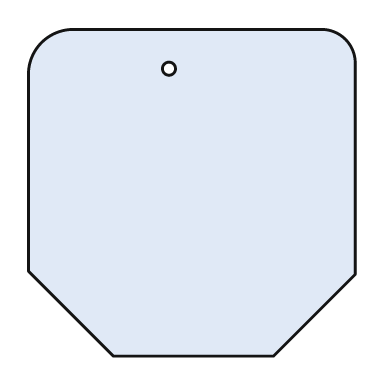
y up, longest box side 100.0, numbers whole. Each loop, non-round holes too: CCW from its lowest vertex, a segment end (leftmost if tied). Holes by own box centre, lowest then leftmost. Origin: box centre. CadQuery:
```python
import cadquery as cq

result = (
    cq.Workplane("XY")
    .moveTo(-24.0, -50.0)
    .lineTo(25.0, -50.0)
    .lineTo(50.0, -25.0)
    .lineTo(50.0, 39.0)
    .threePointArc((47.0, 47.0), (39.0, 50.0))
    .lineTo(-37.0, 50.0)
    .threePointArc((-46.0, 46.0), (-50.0, 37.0))
    .lineTo(-50.0, -24.0)
    .close()
    .moveTo(-7.0, 38.0)
    .circle(2.0)
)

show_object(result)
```